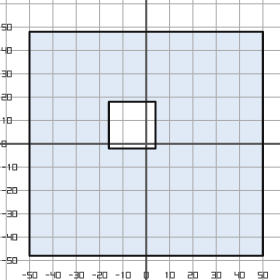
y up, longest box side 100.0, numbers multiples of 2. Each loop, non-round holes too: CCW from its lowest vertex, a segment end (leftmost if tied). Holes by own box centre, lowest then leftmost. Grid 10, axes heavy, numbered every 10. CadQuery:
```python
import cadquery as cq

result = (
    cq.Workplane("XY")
    .moveTo(-50.0, -48.0)
    .lineTo(50.0, -48.0)
    .lineTo(50.0, 48.0)
    .lineTo(-50.0, 48.0)
    .close()
    .moveTo(-16.0, -2.0)
    .lineTo(4.0, -2.0)
    .lineTo(4.0, 18.0)
    .lineTo(-16.0, 18.0)
    .close()
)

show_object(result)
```